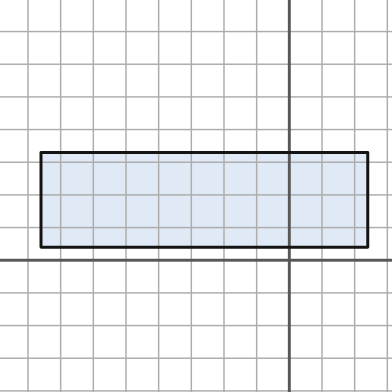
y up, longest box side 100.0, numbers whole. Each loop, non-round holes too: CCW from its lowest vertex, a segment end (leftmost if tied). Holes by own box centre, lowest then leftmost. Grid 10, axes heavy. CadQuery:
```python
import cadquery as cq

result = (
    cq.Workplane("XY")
    .moveTo(-76.0, 4.0)
    .lineTo(24.0, 4.0)
    .lineTo(24.0, 33.0)
    .lineTo(-76.0, 33.0)
    .close()
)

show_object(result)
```